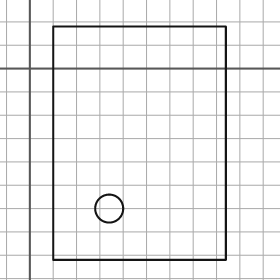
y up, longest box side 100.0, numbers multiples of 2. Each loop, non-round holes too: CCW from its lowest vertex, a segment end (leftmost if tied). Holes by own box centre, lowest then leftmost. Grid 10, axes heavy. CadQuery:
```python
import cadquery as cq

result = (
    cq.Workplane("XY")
    .moveTo(10.0, -82.0)
    .lineTo(84.0, -82.0)
    .lineTo(84.0, 18.0)
    .lineTo(10.0, 18.0)
    .close()
    .moveTo(34.0, -60.0)
    .circle(6.0)
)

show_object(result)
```